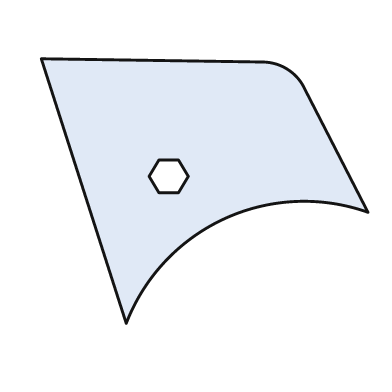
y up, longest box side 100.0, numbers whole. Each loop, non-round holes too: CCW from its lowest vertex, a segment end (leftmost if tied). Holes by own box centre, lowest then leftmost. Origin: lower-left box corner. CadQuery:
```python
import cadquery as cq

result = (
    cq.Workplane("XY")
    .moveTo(26.0, 0.0)
    .threePointArc((56.0, 32.0), (100.0, 34.0))
    .lineTo(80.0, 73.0)
    .threePointArc((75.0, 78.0), (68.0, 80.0))
    .lineTo(0.0, 81.0)
    .close()
    .moveTo(36.0, 40.0)
    .lineTo(42.0, 40.0)
    .lineTo(45.0, 45.0)
    .lineTo(42.0, 50.0)
    .lineTo(36.0, 50.0)
    .lineTo(33.0, 45.0)
    .close()
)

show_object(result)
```